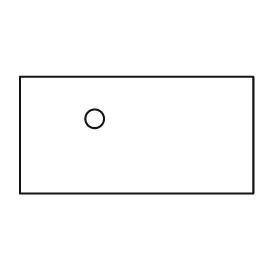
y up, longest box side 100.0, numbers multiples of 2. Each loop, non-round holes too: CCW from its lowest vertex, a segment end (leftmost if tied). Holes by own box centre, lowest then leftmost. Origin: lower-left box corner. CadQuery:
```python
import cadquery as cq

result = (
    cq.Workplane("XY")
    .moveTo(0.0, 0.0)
    .lineTo(100.0, 0.0)
    .lineTo(100.0, 50.0)
    .lineTo(0.0, 50.0)
    .close()
    .moveTo(32.0, 32.0)
    .circle(4.0)
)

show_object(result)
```